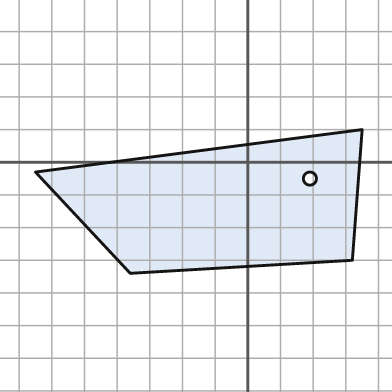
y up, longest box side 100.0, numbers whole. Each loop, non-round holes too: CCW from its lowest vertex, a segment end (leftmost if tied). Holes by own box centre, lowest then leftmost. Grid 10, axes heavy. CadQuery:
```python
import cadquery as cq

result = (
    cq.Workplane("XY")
    .moveTo(-36.0, -34.0)
    .lineTo(32.0, -30.0)
    .lineTo(35.0, 10.0)
    .lineTo(-65.0, -3.0)
    .close()
    .moveTo(19.0, -5.0)
    .circle(2.0)
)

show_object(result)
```